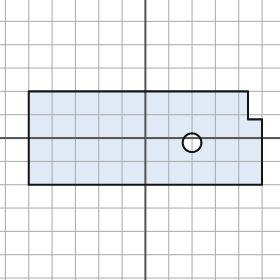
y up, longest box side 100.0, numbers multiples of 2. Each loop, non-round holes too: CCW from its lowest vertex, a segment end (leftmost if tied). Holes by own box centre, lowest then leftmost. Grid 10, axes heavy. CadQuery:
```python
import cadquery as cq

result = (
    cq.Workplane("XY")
    .moveTo(-50.0, -20.0)
    .lineTo(50.0, -20.0)
    .lineTo(50.0, 8.0)
    .lineTo(44.0, 8.0)
    .lineTo(44.0, 20.0)
    .lineTo(-50.0, 20.0)
    .close()
    .moveTo(20.0, -2.0)
    .circle(4.0)
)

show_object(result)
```